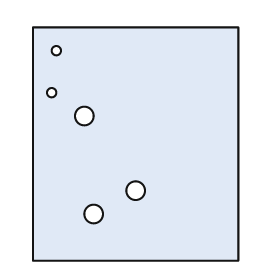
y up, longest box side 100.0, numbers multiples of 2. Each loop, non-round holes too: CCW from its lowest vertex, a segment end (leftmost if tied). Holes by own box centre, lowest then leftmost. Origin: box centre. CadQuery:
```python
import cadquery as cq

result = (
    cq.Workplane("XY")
    .moveTo(-44.0, -50.0)
    .lineTo(44.0, -50.0)
    .lineTo(44.0, 50.0)
    .lineTo(-44.0, 50.0)
    .close()
    .moveTo(-18.0, -30.0)
    .circle(4.0)
    .moveTo(0.0, -20.0)
    .circle(4.0)
    .moveTo(-22.0, 12.0)
    .circle(4.0)
    .moveTo(-36.0, 22.0)
    .circle(2.0)
    .moveTo(-34.0, 40.0)
    .circle(2.0)
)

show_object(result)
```